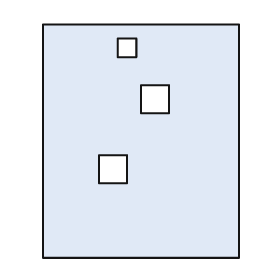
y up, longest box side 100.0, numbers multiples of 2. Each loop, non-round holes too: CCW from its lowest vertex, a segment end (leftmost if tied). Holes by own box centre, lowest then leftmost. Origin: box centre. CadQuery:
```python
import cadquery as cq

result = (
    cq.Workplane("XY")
    .moveTo(-42.0, -50.0)
    .lineTo(42.0, -50.0)
    .lineTo(42.0, 50.0)
    .lineTo(-42.0, 50.0)
    .close()
    .moveTo(-18.0, -18.0)
    .lineTo(-6.0, -18.0)
    .lineTo(-6.0, -6.0)
    .lineTo(-18.0, -6.0)
    .close()
    .moveTo(0.0, 12.0)
    .lineTo(12.0, 12.0)
    .lineTo(12.0, 24.0)
    .lineTo(0.0, 24.0)
    .close()
    .moveTo(-10.0, 36.0)
    .lineTo(-2.0, 36.0)
    .lineTo(-2.0, 44.0)
    .lineTo(-10.0, 44.0)
    .close()
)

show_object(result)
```